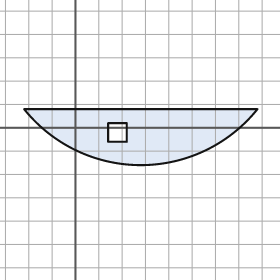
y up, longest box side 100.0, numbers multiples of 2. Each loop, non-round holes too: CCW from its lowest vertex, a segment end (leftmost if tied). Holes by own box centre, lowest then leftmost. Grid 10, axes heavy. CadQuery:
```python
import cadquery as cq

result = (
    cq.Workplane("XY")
    .moveTo(-22.0, 8.0)
    .threePointArc((28.0, -16.0), (78.0, 8.0))
    .close()
    .moveTo(14.0, -6.0)
    .lineTo(22.0, -6.0)
    .lineTo(22.0, 2.0)
    .lineTo(14.0, 2.0)
    .close()
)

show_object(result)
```